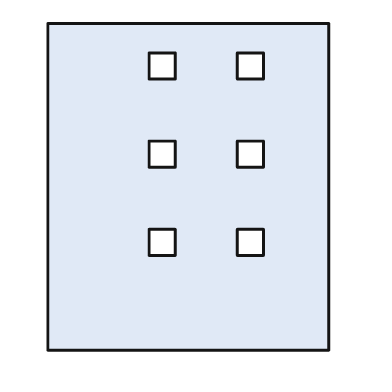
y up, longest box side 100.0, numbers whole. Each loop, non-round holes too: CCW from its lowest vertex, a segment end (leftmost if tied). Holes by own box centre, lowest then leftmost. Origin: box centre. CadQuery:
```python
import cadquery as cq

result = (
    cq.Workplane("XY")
    .moveTo(-43.0, -50.0)
    .lineTo(43.0, -50.0)
    .lineTo(43.0, 50.0)
    .lineTo(-43.0, 50.0)
    .close()
    .moveTo(-12.0, -21.0)
    .lineTo(-4.0, -21.0)
    .lineTo(-4.0, -13.0)
    .lineTo(-12.0, -13.0)
    .close()
    .moveTo(15.0, -21.0)
    .lineTo(23.0, -21.0)
    .lineTo(23.0, -13.0)
    .lineTo(15.0, -13.0)
    .close()
    .moveTo(-12.0, 6.0)
    .lineTo(-4.0, 6.0)
    .lineTo(-4.0, 14.0)
    .lineTo(-12.0, 14.0)
    .close()
    .moveTo(15.0, 6.0)
    .lineTo(23.0, 6.0)
    .lineTo(23.0, 14.0)
    .lineTo(15.0, 14.0)
    .close()
    .moveTo(-12.0, 33.0)
    .lineTo(-4.0, 33.0)
    .lineTo(-4.0, 41.0)
    .lineTo(-12.0, 41.0)
    .close()
    .moveTo(15.0, 33.0)
    .lineTo(23.0, 33.0)
    .lineTo(23.0, 41.0)
    .lineTo(15.0, 41.0)
    .close()
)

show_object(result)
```